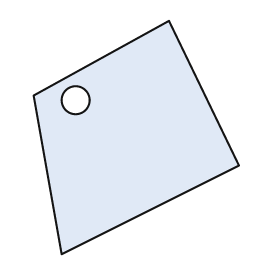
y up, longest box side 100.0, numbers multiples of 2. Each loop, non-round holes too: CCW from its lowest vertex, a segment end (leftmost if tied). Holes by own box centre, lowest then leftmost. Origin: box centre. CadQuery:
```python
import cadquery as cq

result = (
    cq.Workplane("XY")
    .moveTo(-32.0, -50.0)
    .lineTo(44.0, -12.0)
    .lineTo(14.0, 50.0)
    .lineTo(-44.0, 18.0)
    .close()
    .moveTo(-26.0, 16.0)
    .circle(6.0)
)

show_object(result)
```